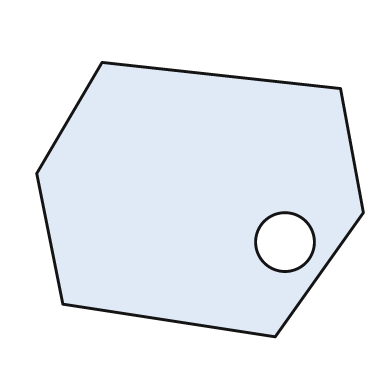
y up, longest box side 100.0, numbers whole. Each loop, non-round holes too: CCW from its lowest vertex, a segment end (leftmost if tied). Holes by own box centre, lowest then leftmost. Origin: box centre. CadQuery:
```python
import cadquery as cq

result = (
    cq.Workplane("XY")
    .moveTo(23.0, -42.0)
    .lineTo(50.0, -4.0)
    .lineTo(43.0, 34.0)
    .lineTo(-30.0, 42.0)
    .lineTo(-50.0, 8.0)
    .lineTo(-42.0, -32.0)
    .close()
    .moveTo(26.0, -13.0)
    .circle(9.0)
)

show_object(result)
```